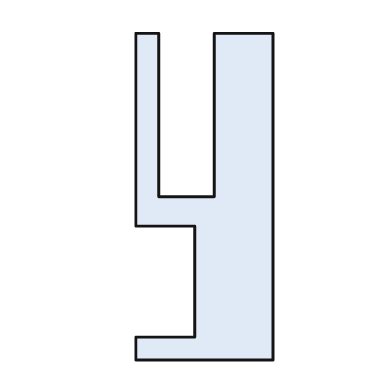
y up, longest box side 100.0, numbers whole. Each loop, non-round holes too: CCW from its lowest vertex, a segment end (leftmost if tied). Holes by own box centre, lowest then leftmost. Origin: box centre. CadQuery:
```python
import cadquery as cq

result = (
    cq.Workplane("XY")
    .moveTo(-21.0, -50.0)
    .lineTo(21.0, -50.0)
    .lineTo(21.0, 50.0)
    .lineTo(3.0, 50.0)
    .lineTo(3.0, 0.0)
    .lineTo(-14.0, 0.0)
    .lineTo(-14.0, 50.0)
    .lineTo(-21.0, 50.0)
    .lineTo(-21.0, -9.0)
    .lineTo(-3.0, -9.0)
    .lineTo(-3.0, -43.0)
    .lineTo(-21.0, -43.0)
    .close()
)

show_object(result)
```